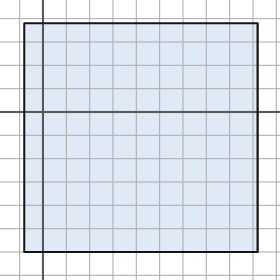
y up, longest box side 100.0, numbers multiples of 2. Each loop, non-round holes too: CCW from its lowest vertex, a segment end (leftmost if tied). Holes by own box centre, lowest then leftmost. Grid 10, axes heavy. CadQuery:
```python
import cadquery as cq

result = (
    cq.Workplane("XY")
    .moveTo(-8.0, -60.0)
    .lineTo(92.0, -60.0)
    .lineTo(92.0, 38.0)
    .lineTo(-8.0, 38.0)
    .close()
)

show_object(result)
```